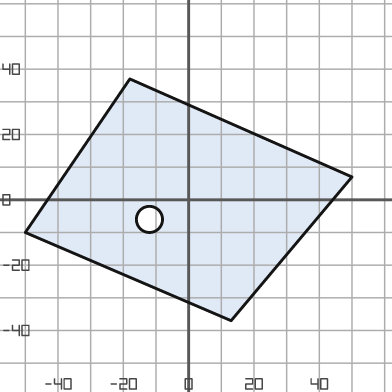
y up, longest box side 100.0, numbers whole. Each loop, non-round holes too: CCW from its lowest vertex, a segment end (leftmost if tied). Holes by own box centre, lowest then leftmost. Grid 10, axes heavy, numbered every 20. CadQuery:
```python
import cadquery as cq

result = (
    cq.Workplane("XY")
    .moveTo(13.0, -37.0)
    .lineTo(50.0, 7.0)
    .lineTo(-18.0, 37.0)
    .lineTo(-50.0, -10.0)
    .close()
    .moveTo(-12.0, -6.0)
    .circle(4.0)
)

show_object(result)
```